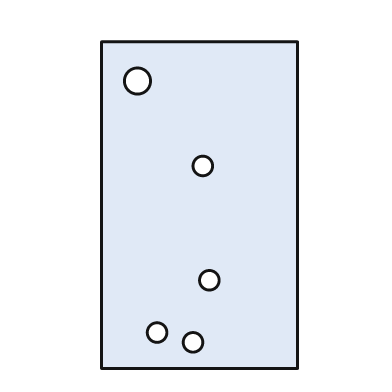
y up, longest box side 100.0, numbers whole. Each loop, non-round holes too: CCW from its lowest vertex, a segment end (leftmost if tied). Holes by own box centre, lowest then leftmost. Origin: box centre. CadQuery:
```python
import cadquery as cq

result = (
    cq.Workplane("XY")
    .moveTo(-30.0, -50.0)
    .lineTo(30.0, -50.0)
    .lineTo(30.0, 50.0)
    .lineTo(-30.0, 50.0)
    .close()
    .moveTo(-2.0, -42.0)
    .circle(3.0)
    .moveTo(-13.0, -39.0)
    .circle(3.0)
    .moveTo(3.0, -23.0)
    .circle(3.0)
    .moveTo(1.0, 12.0)
    .circle(3.0)
    .moveTo(-19.0, 38.0)
    .circle(4.0)
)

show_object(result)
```